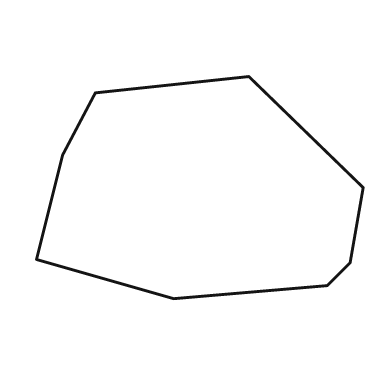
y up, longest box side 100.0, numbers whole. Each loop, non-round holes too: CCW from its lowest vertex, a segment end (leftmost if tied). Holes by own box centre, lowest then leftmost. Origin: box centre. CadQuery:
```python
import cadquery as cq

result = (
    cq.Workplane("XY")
    .moveTo(-8.0, -34.0)
    .lineTo(39.0, -30.0)
    .lineTo(46.0, -23.0)
    .lineTo(50.0, 0.0)
    .lineTo(15.0, 34.0)
    .lineTo(-32.0, 29.0)
    .lineTo(-42.0, 10.0)
    .lineTo(-50.0, -22.0)
    .close()
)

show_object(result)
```